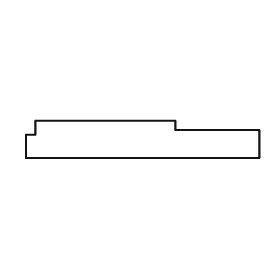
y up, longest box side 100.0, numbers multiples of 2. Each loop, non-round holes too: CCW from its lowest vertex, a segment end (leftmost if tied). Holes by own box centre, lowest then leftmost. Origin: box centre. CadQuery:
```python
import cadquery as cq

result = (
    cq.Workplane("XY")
    .moveTo(-50.0, -8.0)
    .lineTo(50.0, -8.0)
    .lineTo(50.0, 4.0)
    .lineTo(14.0, 4.0)
    .lineTo(14.0, 8.0)
    .lineTo(-46.0, 8.0)
    .lineTo(-46.0, 2.0)
    .lineTo(-50.0, 2.0)
    .close()
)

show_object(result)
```